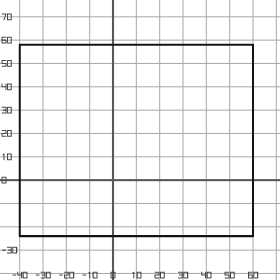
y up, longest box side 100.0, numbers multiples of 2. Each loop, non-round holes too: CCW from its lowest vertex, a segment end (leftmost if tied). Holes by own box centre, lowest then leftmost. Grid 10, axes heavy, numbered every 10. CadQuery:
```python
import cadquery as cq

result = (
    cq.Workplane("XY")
    .moveTo(-40.0, -24.0)
    .lineTo(60.0, -24.0)
    .lineTo(60.0, 58.0)
    .lineTo(-40.0, 58.0)
    .close()
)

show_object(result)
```